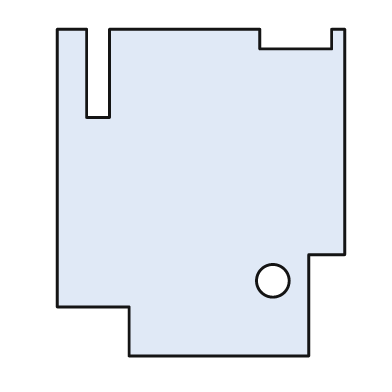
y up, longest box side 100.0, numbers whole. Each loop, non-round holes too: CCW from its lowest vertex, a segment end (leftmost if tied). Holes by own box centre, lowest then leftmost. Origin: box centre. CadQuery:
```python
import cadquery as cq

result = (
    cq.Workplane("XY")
    .moveTo(-22.0, -50.0)
    .lineTo(33.0, -50.0)
    .lineTo(33.0, -19.0)
    .lineTo(44.0, -19.0)
    .lineTo(44.0, 50.0)
    .lineTo(40.0, 50.0)
    .lineTo(40.0, 44.0)
    .lineTo(18.0, 44.0)
    .lineTo(18.0, 50.0)
    .lineTo(-28.0, 50.0)
    .lineTo(-28.0, 23.0)
    .lineTo(-35.0, 23.0)
    .lineTo(-35.0, 50.0)
    .lineTo(-44.0, 50.0)
    .lineTo(-44.0, -35.0)
    .lineTo(-22.0, -35.0)
    .close()
    .moveTo(22.0, -27.0)
    .circle(5.0)
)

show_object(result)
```